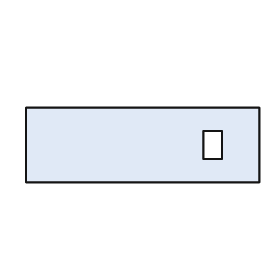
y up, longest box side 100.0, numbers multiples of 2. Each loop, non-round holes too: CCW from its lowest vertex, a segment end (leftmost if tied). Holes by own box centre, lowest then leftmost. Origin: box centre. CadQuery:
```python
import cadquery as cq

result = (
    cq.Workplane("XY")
    .moveTo(-50.0, -16.0)
    .lineTo(50.0, -16.0)
    .lineTo(50.0, 16.0)
    .lineTo(-50.0, 16.0)
    .close()
    .moveTo(26.0, -6.0)
    .lineTo(34.0, -6.0)
    .lineTo(34.0, 6.0)
    .lineTo(26.0, 6.0)
    .close()
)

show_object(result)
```